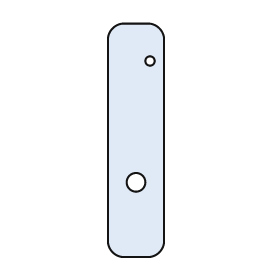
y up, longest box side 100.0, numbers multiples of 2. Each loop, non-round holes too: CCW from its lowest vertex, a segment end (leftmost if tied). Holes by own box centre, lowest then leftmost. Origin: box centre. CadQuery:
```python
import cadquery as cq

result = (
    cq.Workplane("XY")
    .moveTo(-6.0, -50.0)
    .lineTo(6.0, -50.0)
    .threePointArc((10.0, -48.0), (12.0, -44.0))
    .lineTo(12.0, 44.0)
    .threePointArc((10.0, 48.0), (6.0, 50.0))
    .lineTo(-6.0, 50.0)
    .threePointArc((-10.0, 48.0), (-12.0, 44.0))
    .lineTo(-12.0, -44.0)
    .threePointArc((-10.0, -48.0), (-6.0, -50.0))
    .close()
    .moveTo(0.0, -18.0)
    .circle(4.0)
    .moveTo(6.0, 34.0)
    .circle(2.0)
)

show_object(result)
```